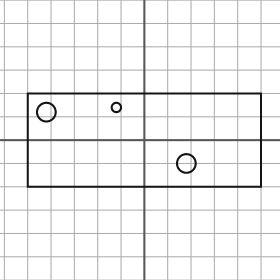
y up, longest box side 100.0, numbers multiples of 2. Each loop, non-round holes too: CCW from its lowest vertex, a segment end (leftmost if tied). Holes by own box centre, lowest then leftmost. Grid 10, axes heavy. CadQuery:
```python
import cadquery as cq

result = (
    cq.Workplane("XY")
    .moveTo(-50.0, -20.0)
    .lineTo(50.0, -20.0)
    .lineTo(50.0, 20.0)
    .lineTo(-50.0, 20.0)
    .close()
    .moveTo(18.0, -10.0)
    .circle(4.0)
    .moveTo(-42.0, 12.0)
    .circle(4.0)
    .moveTo(-12.0, 14.0)
    .circle(2.0)
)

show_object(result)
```